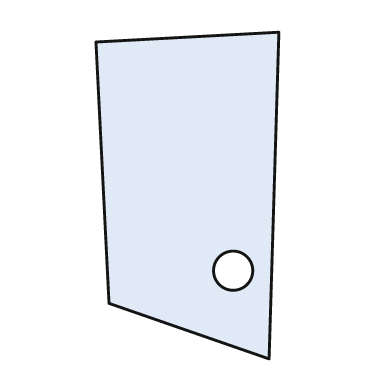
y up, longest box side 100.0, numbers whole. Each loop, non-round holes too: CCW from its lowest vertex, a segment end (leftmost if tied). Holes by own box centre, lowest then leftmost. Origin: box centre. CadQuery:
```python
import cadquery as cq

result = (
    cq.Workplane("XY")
    .moveTo(25.0, -50.0)
    .lineTo(28.0, 50.0)
    .lineTo(-28.0, 47.0)
    .lineTo(-24.0, -33.0)
    .close()
    .moveTo(14.0, -23.0)
    .circle(6.0)
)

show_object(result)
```